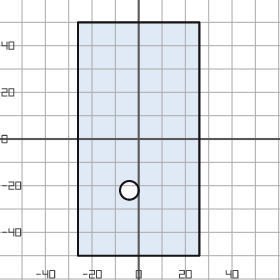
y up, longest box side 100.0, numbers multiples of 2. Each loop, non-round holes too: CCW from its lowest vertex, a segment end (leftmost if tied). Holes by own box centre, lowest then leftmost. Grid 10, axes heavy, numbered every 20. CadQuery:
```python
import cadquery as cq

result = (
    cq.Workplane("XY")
    .moveTo(-26.0, -50.0)
    .lineTo(26.0, -50.0)
    .lineTo(26.0, 50.0)
    .lineTo(-26.0, 50.0)
    .close()
    .moveTo(-4.0, -22.0)
    .circle(4.0)
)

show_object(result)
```